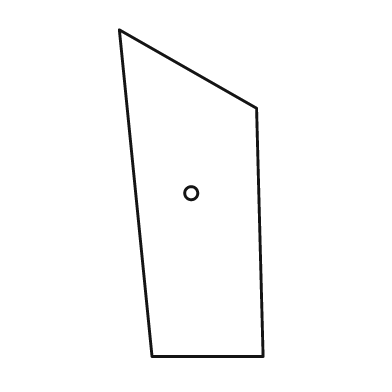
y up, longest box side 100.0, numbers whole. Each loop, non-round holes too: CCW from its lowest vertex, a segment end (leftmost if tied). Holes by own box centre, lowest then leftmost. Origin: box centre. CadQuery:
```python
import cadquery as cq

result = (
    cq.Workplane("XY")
    .moveTo(-12.0, -50.0)
    .lineTo(22.0, -50.0)
    .lineTo(20.0, 26.0)
    .lineTo(-22.0, 50.0)
    .close()
    .moveTo(0.0, 0.0)
    .circle(2.0)
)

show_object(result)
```